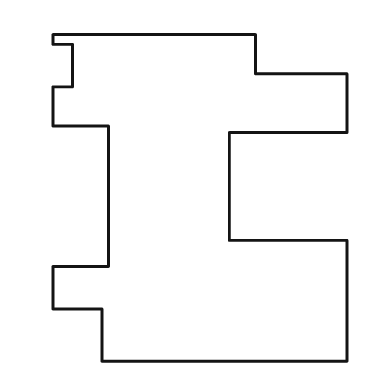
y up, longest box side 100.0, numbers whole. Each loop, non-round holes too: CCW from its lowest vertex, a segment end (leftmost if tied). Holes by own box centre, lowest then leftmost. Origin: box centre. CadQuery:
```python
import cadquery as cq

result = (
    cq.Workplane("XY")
    .moveTo(-30.0, -50.0)
    .lineTo(45.0, -50.0)
    .lineTo(45.0, -13.0)
    .lineTo(9.0, -13.0)
    .lineTo(9.0, 20.0)
    .lineTo(45.0, 20.0)
    .lineTo(45.0, 38.0)
    .lineTo(17.0, 38.0)
    .lineTo(17.0, 50.0)
    .lineTo(-45.0, 50.0)
    .lineTo(-45.0, 47.0)
    .lineTo(-39.0, 47.0)
    .lineTo(-39.0, 34.0)
    .lineTo(-45.0, 34.0)
    .lineTo(-45.0, 22.0)
    .lineTo(-28.0, 22.0)
    .lineTo(-28.0, -21.0)
    .lineTo(-45.0, -21.0)
    .lineTo(-45.0, -34.0)
    .lineTo(-30.0, -34.0)
    .close()
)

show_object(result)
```